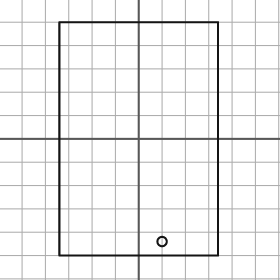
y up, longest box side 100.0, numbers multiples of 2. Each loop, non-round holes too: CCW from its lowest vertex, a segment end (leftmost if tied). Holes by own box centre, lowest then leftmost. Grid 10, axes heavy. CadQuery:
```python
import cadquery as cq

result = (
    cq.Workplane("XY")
    .moveTo(-34.0, -50.0)
    .lineTo(34.0, -50.0)
    .lineTo(34.0, 50.0)
    .lineTo(-34.0, 50.0)
    .close()
    .moveTo(10.0, -44.0)
    .circle(2.0)
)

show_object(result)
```